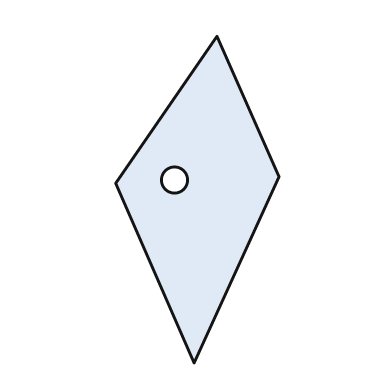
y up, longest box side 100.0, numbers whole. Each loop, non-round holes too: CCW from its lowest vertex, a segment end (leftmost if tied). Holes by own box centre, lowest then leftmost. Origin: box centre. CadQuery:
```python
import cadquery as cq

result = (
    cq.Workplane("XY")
    .moveTo(-1.0, -50.0)
    .lineTo(25.0, 7.0)
    .lineTo(6.0, 50.0)
    .lineTo(-25.0, 5.0)
    .close()
    .moveTo(-7.0, 6.0)
    .circle(4.0)
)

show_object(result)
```